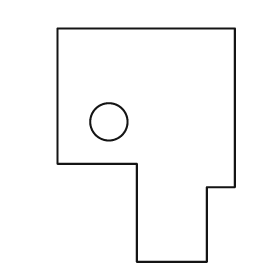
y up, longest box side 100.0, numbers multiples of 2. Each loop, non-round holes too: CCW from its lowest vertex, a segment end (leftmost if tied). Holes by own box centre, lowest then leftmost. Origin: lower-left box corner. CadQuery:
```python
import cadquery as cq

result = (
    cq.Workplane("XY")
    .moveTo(34.0, 0.0)
    .lineTo(64.0, 0.0)
    .lineTo(64.0, 32.0)
    .lineTo(76.0, 32.0)
    .lineTo(76.0, 100.0)
    .lineTo(0.0, 100.0)
    .lineTo(0.0, 42.0)
    .lineTo(34.0, 42.0)
    .close()
    .moveTo(22.0, 60.0)
    .circle(8.0)
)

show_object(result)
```